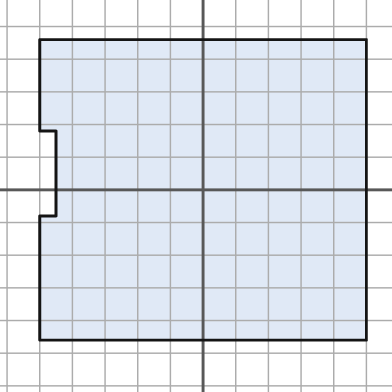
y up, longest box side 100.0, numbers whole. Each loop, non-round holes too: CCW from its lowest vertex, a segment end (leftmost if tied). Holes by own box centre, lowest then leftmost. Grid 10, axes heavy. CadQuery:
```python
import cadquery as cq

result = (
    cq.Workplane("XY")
    .moveTo(-50.0, -46.0)
    .lineTo(50.0, -46.0)
    .lineTo(50.0, 46.0)
    .lineTo(-50.0, 46.0)
    .lineTo(-50.0, 18.0)
    .lineTo(-45.0, 18.0)
    .lineTo(-45.0, -8.0)
    .lineTo(-50.0, -8.0)
    .close()
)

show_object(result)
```